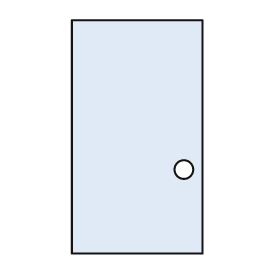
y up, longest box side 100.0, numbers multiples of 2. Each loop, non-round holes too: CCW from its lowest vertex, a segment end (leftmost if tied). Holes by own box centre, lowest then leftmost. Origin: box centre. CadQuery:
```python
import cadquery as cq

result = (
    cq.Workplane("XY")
    .moveTo(-28.0, -50.0)
    .lineTo(28.0, -50.0)
    .lineTo(28.0, 50.0)
    .lineTo(-28.0, 50.0)
    .close()
    .moveTo(20.0, -14.0)
    .circle(4.0)
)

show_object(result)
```